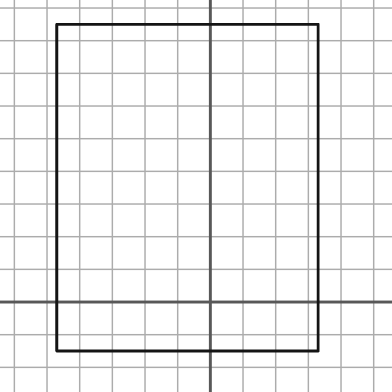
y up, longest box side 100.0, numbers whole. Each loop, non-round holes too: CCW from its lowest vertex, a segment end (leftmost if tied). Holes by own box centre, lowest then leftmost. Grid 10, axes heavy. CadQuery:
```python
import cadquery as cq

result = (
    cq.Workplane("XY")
    .moveTo(-47.0, -15.0)
    .lineTo(33.0, -15.0)
    .lineTo(33.0, 85.0)
    .lineTo(-47.0, 85.0)
    .close()
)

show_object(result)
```